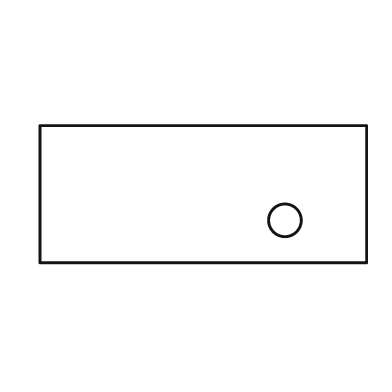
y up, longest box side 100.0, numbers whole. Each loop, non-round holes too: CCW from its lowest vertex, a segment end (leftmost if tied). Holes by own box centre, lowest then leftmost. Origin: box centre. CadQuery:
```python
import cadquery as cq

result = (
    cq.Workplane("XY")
    .moveTo(-50.0, -21.0)
    .lineTo(50.0, -21.0)
    .lineTo(50.0, 21.0)
    .lineTo(-50.0, 21.0)
    .close()
    .moveTo(25.0, -8.0)
    .circle(5.0)
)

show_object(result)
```